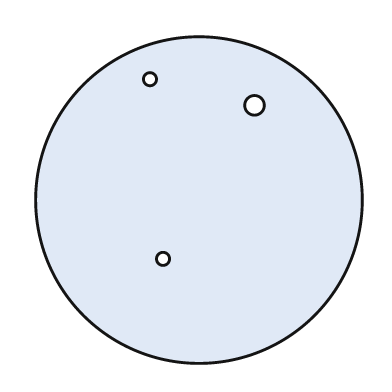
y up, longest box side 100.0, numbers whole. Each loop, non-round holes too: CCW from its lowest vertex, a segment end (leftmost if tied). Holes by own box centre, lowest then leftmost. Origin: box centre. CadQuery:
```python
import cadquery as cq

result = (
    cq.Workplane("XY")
    .moveTo(0.0, 0.0)
    .circle(50.0)
    .moveTo(-11.0, -18.0)
    .circle(2.0)
    .moveTo(17.0, 29.0)
    .circle(3.0)
    .moveTo(-15.0, 37.0)
    .circle(2.0)
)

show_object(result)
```